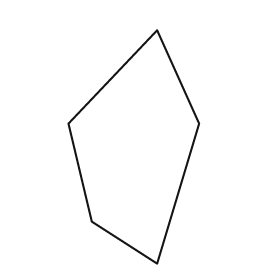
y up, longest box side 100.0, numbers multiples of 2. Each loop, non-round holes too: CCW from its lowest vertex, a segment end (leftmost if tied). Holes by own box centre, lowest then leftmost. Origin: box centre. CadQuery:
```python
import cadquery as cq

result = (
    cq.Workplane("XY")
    .moveTo(10.0, -50.0)
    .lineTo(28.0, 10.0)
    .lineTo(10.0, 50.0)
    .lineTo(-28.0, 10.0)
    .lineTo(-18.0, -32.0)
    .close()
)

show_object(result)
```